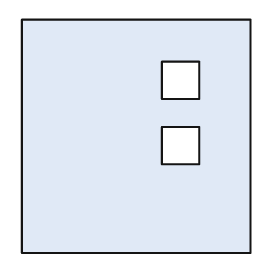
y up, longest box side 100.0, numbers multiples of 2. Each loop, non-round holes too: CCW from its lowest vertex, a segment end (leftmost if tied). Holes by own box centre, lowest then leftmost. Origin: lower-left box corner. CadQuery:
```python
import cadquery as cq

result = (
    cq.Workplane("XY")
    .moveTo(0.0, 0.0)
    .lineTo(98.0, 0.0)
    .lineTo(98.0, 100.0)
    .lineTo(0.0, 100.0)
    .close()
    .moveTo(60.0, 38.0)
    .lineTo(76.0, 38.0)
    .lineTo(76.0, 54.0)
    .lineTo(60.0, 54.0)
    .close()
    .moveTo(60.0, 66.0)
    .lineTo(76.0, 66.0)
    .lineTo(76.0, 82.0)
    .lineTo(60.0, 82.0)
    .close()
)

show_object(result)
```